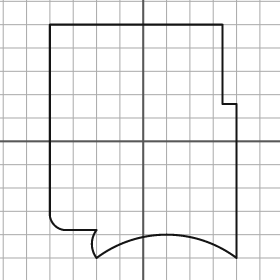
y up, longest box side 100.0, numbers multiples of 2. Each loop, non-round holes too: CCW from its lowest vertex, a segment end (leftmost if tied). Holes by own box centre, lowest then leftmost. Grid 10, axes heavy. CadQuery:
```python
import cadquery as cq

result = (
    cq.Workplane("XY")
    .moveTo(-20.0, -50.0)
    .threePointArc((10.0, -40.0), (40.0, -50.0))
    .lineTo(40.0, 16.0)
    .lineTo(34.0, 16.0)
    .lineTo(34.0, 50.0)
    .lineTo(-40.0, 50.0)
    .lineTo(-40.0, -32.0)
    .threePointArc((-38.0, -36.0), (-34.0, -38.0))
    .lineTo(-20.0, -38.0)
    .threePointArc((-22.0, -44.0), (-20.0, -50.0))
    .close()
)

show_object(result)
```